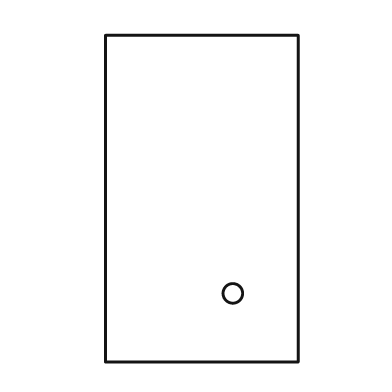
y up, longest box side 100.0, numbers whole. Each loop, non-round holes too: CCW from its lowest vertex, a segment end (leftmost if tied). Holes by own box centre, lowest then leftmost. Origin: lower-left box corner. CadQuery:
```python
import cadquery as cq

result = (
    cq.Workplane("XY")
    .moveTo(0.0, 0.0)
    .lineTo(59.0, 0.0)
    .lineTo(59.0, 100.0)
    .lineTo(0.0, 100.0)
    .close()
    .moveTo(39.0, 21.0)
    .circle(3.0)
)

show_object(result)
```